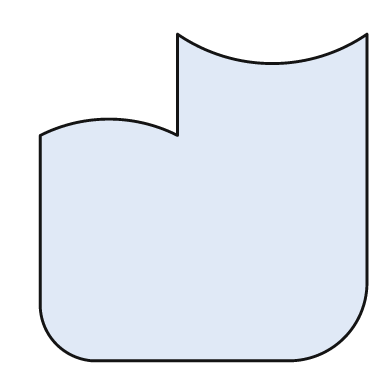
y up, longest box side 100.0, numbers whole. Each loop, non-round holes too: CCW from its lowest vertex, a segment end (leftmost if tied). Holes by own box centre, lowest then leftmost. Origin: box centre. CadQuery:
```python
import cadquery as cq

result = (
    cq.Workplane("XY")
    .moveTo(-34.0, -50.0)
    .lineTo(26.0, -50.0)
    .threePointArc((43.0, -43.0), (50.0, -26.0))
    .lineTo(50.0, 50.0)
    .threePointArc((21.0, 41.0), (-8.0, 50.0))
    .lineTo(-8.0, 19.0)
    .threePointArc((-29.0, 24.0), (-50.0, 19.0))
    .lineTo(-50.0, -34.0)
    .threePointArc((-45.0, -45.0), (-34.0, -50.0))
    .close()
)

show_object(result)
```